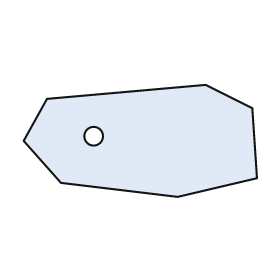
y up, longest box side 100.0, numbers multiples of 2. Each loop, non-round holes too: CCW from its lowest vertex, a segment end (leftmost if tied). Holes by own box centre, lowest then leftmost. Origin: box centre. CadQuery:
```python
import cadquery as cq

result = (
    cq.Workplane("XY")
    .moveTo(16.0, -24.0)
    .lineTo(50.0, -16.0)
    .lineTo(48.0, 14.0)
    .lineTo(28.0, 24.0)
    .lineTo(-40.0, 18.0)
    .lineTo(-50.0, 0.0)
    .lineTo(-34.0, -18.0)
    .close()
    .moveTo(-20.0, 2.0)
    .circle(4.0)
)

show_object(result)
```